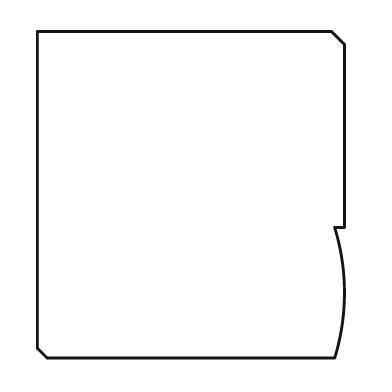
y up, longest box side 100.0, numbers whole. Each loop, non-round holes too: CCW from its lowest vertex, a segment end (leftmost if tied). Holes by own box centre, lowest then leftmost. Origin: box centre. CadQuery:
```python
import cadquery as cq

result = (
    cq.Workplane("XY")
    .moveTo(-44.0, -50.0)
    .lineTo(44.0, -50.0)
    .threePointArc((47.0, -30.0), (44.0, -10.0))
    .lineTo(47.0, -10.0)
    .lineTo(47.0, 46.0)
    .lineTo(43.0, 50.0)
    .lineTo(-47.0, 50.0)
    .lineTo(-47.0, -47.0)
    .close()
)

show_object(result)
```